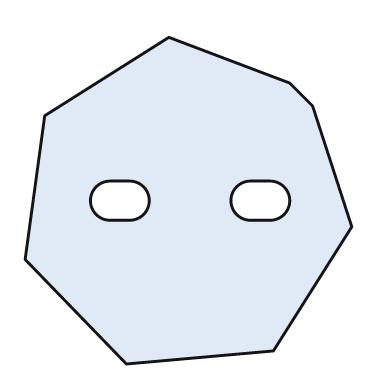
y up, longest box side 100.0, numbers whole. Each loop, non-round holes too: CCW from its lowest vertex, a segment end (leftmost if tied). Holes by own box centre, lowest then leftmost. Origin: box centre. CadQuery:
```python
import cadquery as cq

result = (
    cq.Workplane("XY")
    .moveTo(-19.0, -50.0)
    .lineTo(26.0, -46.0)
    .lineTo(50.0, -8.0)
    .lineTo(38.0, 29.0)
    .lineTo(31.0, 36.0)
    .lineTo(-6.0, 50.0)
    .lineTo(-44.0, 26.0)
    .lineTo(-50.0, -18.0)
    .close()
    .moveTo(-24.0, -6.0)
    .lineTo(-18.0, -6.0)
    .threePointArc((-12.0, 0.0), (-18.0, 6.0))
    .lineTo(-24.0, 6.0)
    .threePointArc((-30.0, 0.0), (-24.0, -6.0))
    .close()
    .moveTo(19.0, -6.0)
    .lineTo(25.0, -6.0)
    .threePointArc((31.0, 0.0), (25.0, 6.0))
    .lineTo(19.0, 6.0)
    .threePointArc((13.0, 0.0), (19.0, -6.0))
    .close()
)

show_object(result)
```